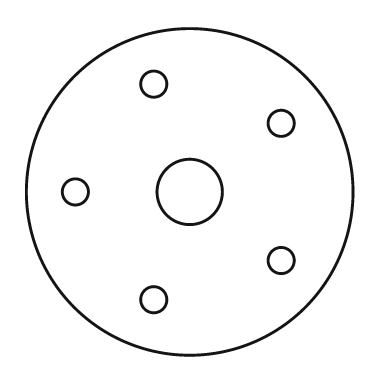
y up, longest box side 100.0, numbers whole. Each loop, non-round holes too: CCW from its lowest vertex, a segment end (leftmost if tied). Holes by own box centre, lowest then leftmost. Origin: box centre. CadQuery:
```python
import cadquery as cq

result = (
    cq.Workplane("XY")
    .moveTo(0.0, 0.0)
    .circle(50.0)
    .moveTo(-11.0, -33.0)
    .circle(4.0)
    .moveTo(28.0, -21.0)
    .circle(4.0)
    .moveTo(-35.0, 0.0)
    .circle(4.0)
    .moveTo(0.0, 0.0)
    .circle(10.0)
    .moveTo(28.0, 21.0)
    .circle(4.0)
    .moveTo(-11.0, 33.0)
    .circle(4.0)
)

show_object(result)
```